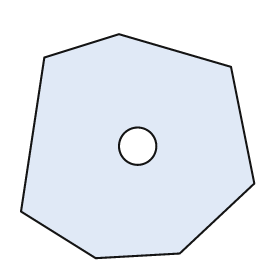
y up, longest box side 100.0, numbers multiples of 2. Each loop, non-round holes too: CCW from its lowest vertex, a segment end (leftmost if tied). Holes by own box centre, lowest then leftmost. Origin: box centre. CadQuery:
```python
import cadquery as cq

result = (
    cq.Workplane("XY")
    .moveTo(-18.0, -48.0)
    .lineTo(18.0, -46.0)
    .lineTo(50.0, -16.0)
    .lineTo(40.0, 34.0)
    .lineTo(-8.0, 48.0)
    .lineTo(-40.0, 38.0)
    .lineTo(-50.0, -28.0)
    .close()
    .moveTo(0.0, 0.0)
    .circle(8.0)
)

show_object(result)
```